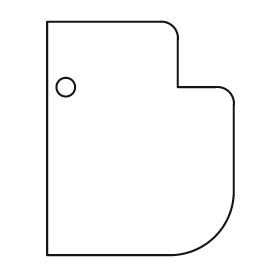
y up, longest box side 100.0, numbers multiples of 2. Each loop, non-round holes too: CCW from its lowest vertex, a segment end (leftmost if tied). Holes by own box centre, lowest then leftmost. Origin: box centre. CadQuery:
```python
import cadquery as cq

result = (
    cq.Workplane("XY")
    .moveTo(-40.0, -50.0)
    .lineTo(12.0, -50.0)
    .threePointArc((32.0, -42.0), (40.0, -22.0))
    .lineTo(40.0, 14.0)
    .threePointArc((38.0, 20.0), (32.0, 22.0))
    .lineTo(16.0, 22.0)
    .lineTo(16.0, 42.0)
    .threePointArc((14.0, 48.0), (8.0, 50.0))
    .lineTo(-40.0, 50.0)
    .close()
    .moveTo(-32.0, 22.0)
    .circle(4.0)
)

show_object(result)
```